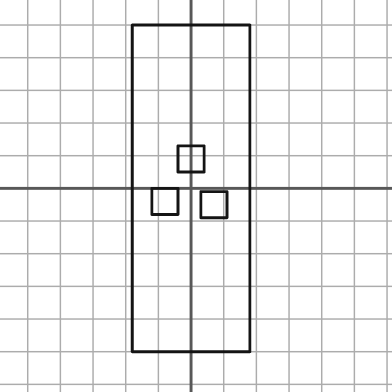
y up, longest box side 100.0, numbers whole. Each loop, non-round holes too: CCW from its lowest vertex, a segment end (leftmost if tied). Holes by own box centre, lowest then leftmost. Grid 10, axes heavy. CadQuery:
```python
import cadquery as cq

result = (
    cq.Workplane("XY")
    .moveTo(-18.0, -50.0)
    .lineTo(18.0, -50.0)
    .lineTo(18.0, 50.0)
    .lineTo(-18.0, 50.0)
    .close()
    .moveTo(3.0, -9.0)
    .lineTo(11.0, -9.0)
    .lineTo(11.0, -1.0)
    .lineTo(3.0, -1.0)
    .close()
    .moveTo(-12.0, -8.0)
    .lineTo(-4.0, -8.0)
    .lineTo(-4.0, 0.0)
    .lineTo(-12.0, 0.0)
    .close()
    .moveTo(-4.0, 5.0)
    .lineTo(4.0, 5.0)
    .lineTo(4.0, 13.0)
    .lineTo(-4.0, 13.0)
    .close()
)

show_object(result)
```